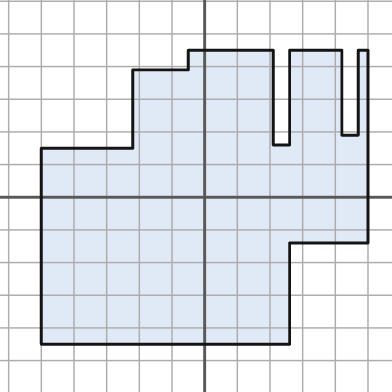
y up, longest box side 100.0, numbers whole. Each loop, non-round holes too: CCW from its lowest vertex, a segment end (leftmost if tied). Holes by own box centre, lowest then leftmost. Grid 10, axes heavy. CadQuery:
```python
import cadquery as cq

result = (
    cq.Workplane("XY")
    .moveTo(-50.0, -45.0)
    .lineTo(26.0, -45.0)
    .lineTo(26.0, -14.0)
    .lineTo(50.0, -14.0)
    .lineTo(50.0, 45.0)
    .lineTo(47.0, 45.0)
    .lineTo(47.0, 19.0)
    .lineTo(42.0, 19.0)
    .lineTo(42.0, 45.0)
    .lineTo(26.0, 45.0)
    .lineTo(26.0, 16.0)
    .lineTo(21.0, 16.0)
    .lineTo(21.0, 45.0)
    .lineTo(-5.0, 45.0)
    .lineTo(-5.0, 39.0)
    .lineTo(-22.0, 39.0)
    .lineTo(-22.0, 15.0)
    .lineTo(-50.0, 15.0)
    .close()
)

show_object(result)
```